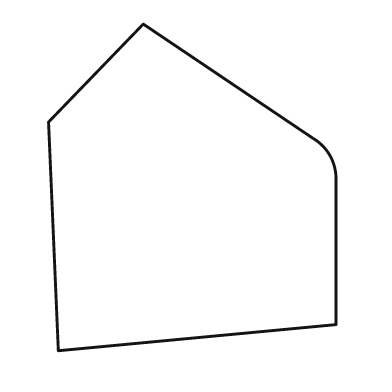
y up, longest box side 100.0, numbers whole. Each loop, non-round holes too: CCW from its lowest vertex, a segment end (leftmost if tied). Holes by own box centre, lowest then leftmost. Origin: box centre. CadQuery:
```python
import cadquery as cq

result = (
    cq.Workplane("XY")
    .moveTo(-41.0, -50.0)
    .lineTo(44.0, -42.0)
    .lineTo(44.0, 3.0)
    .threePointArc((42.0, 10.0), (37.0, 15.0))
    .lineTo(-15.0, 50.0)
    .lineTo(-44.0, 20.0)
    .close()
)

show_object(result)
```